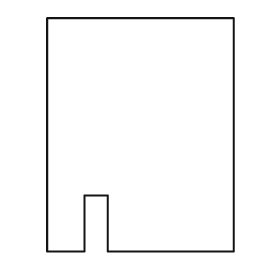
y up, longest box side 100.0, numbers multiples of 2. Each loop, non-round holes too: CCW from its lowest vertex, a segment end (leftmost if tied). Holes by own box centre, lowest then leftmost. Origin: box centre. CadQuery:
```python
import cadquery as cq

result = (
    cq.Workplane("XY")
    .moveTo(-40.0, -50.0)
    .lineTo(-24.0, -50.0)
    .lineTo(-24.0, -26.0)
    .lineTo(-14.0, -26.0)
    .lineTo(-14.0, -50.0)
    .lineTo(40.0, -50.0)
    .lineTo(40.0, 50.0)
    .lineTo(-40.0, 50.0)
    .close()
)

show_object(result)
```